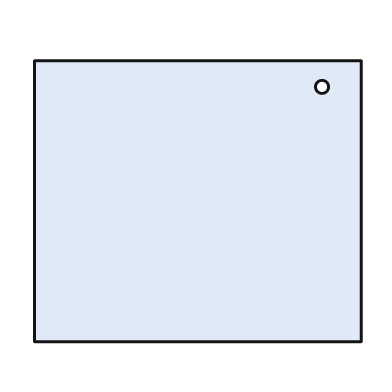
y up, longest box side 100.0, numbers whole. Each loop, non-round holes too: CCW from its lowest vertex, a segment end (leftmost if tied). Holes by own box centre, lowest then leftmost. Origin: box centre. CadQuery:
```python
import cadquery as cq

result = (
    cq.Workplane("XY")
    .moveTo(-50.0, -43.0)
    .lineTo(50.0, -43.0)
    .lineTo(50.0, 43.0)
    .lineTo(-50.0, 43.0)
    .close()
    .moveTo(38.0, 35.0)
    .circle(2.0)
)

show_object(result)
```